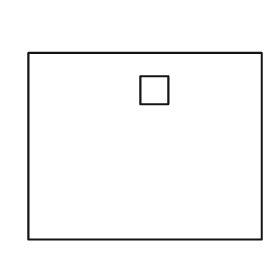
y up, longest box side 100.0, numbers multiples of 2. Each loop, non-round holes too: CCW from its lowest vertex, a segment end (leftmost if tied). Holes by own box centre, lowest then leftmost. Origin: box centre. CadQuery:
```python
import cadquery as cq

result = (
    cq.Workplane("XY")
    .moveTo(-50.0, -40.0)
    .lineTo(50.0, -40.0)
    .lineTo(50.0, 40.0)
    .lineTo(-50.0, 40.0)
    .close()
    .moveTo(-2.0, 18.0)
    .lineTo(10.0, 18.0)
    .lineTo(10.0, 30.0)
    .lineTo(-2.0, 30.0)
    .close()
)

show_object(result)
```